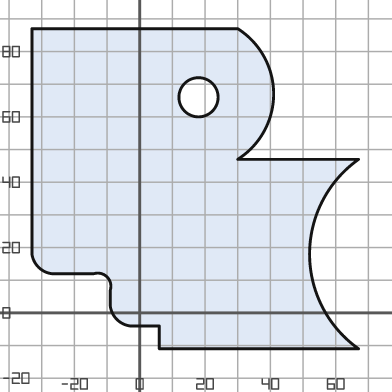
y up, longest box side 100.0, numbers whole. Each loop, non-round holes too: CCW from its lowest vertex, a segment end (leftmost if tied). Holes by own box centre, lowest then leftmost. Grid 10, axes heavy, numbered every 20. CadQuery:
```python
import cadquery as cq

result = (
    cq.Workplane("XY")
    .moveTo(6.0, -11.0)
    .lineTo(67.0, -11.0)
    .threePointArc((52.0, 18.0), (67.0, 47.0))
    .lineTo(30.0, 47.0)
    .threePointArc((41.0, 67.0), (30.0, 87.0))
    .lineTo(-33.0, 87.0)
    .lineTo(-33.0, 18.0)
    .threePointArc((-31.0, 14.0), (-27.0, 12.0))
    .lineTo(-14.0, 12.0)
    .threePointArc((-10.0, 11.0), (-9.0, 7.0))
    .lineTo(-9.0, 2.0)
    .threePointArc((-7.0, -2.0), (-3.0, -4.0))
    .lineTo(6.0, -4.0)
    .close()
    .moveTo(18.0, 66.0)
    .circle(6.0)
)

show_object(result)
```